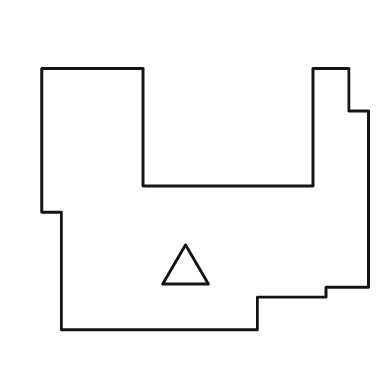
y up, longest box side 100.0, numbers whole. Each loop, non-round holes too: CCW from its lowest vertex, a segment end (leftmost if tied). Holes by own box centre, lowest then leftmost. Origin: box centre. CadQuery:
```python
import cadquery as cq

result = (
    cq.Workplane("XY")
    .moveTo(-44.0, -40.0)
    .lineTo(16.0, -40.0)
    .lineTo(16.0, -30.0)
    .lineTo(37.0, -30.0)
    .lineTo(37.0, -27.0)
    .lineTo(50.0, -27.0)
    .lineTo(50.0, 27.0)
    .lineTo(44.0, 27.0)
    .lineTo(44.0, 40.0)
    .lineTo(33.0, 40.0)
    .lineTo(33.0, 4.0)
    .lineTo(-19.0, 4.0)
    .lineTo(-19.0, 40.0)
    .lineTo(-50.0, 40.0)
    .lineTo(-50.0, -4.0)
    .lineTo(-44.0, -4.0)
    .close()
    .moveTo(-13.0, -26.0)
    .lineTo(1.0, -26.0)
    .lineTo(-6.0, -14.0)
    .close()
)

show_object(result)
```